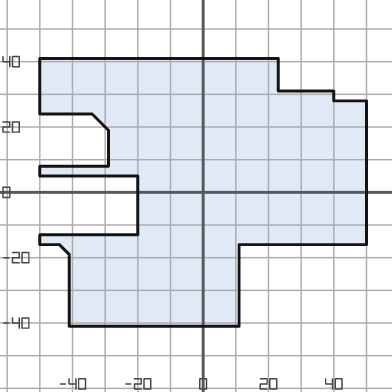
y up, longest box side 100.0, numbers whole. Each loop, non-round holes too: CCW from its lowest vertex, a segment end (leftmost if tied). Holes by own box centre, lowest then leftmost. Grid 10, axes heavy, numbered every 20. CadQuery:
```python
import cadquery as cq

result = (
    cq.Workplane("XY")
    .moveTo(-41.0, -41.0)
    .lineTo(11.0, -41.0)
    .lineTo(11.0, -16.0)
    .lineTo(50.0, -16.0)
    .lineTo(50.0, 28.0)
    .lineTo(40.0, 28.0)
    .lineTo(40.0, 31.0)
    .lineTo(23.0, 31.0)
    .lineTo(23.0, 41.0)
    .lineTo(-50.0, 41.0)
    .lineTo(-50.0, 24.0)
    .lineTo(-34.0, 24.0)
    .lineTo(-29.0, 19.0)
    .lineTo(-29.0, 8.0)
    .lineTo(-50.0, 8.0)
    .lineTo(-50.0, 5.0)
    .lineTo(-20.0, 5.0)
    .lineTo(-20.0, -13.0)
    .lineTo(-50.0, -13.0)
    .lineTo(-50.0, -16.0)
    .lineTo(-44.0, -16.0)
    .lineTo(-41.0, -19.0)
    .close()
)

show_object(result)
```